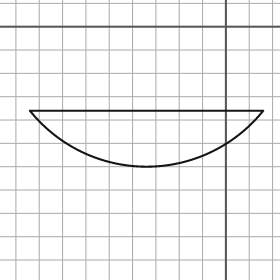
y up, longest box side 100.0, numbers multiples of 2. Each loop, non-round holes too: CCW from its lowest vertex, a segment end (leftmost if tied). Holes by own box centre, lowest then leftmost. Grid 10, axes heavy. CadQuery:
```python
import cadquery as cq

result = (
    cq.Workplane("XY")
    .moveTo(-84.0, -36.0)
    .threePointArc((-34.0, -60.0), (16.0, -36.0))
    .close()
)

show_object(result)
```